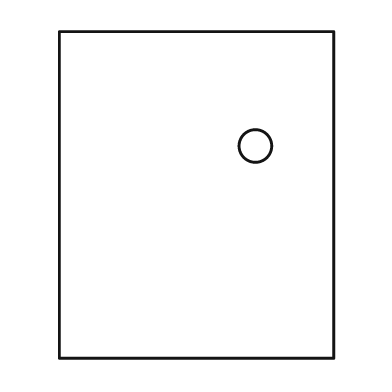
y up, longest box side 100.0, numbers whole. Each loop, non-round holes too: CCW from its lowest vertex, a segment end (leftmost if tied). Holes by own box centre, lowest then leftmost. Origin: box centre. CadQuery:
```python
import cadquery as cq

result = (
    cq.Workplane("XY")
    .moveTo(-42.0, -50.0)
    .lineTo(42.0, -50.0)
    .lineTo(42.0, 50.0)
    .lineTo(-42.0, 50.0)
    .close()
    .moveTo(18.0, 15.0)
    .circle(5.0)
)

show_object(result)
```